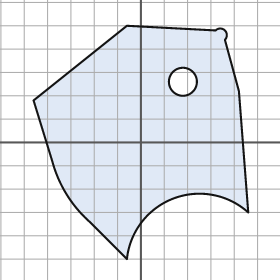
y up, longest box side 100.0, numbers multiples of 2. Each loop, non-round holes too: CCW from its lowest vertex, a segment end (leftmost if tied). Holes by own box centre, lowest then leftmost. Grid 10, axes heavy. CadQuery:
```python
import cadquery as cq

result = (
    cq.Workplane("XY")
    .moveTo(-6.0, -50.0)
    .threePointArc((14.0, -24.0), (46.0, -30.0))
    .lineTo(42.0, 22.0)
    .lineTo(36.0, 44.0)
    .threePointArc((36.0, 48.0), (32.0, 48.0))
    .lineTo(-6.0, 50.0)
    .lineTo(-46.0, 18.0)
    .lineTo(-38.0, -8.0)
    .threePointArc((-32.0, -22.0), (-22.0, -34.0))
    .close()
    .moveTo(18.0, 26.0)
    .circle(6.0)
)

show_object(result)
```